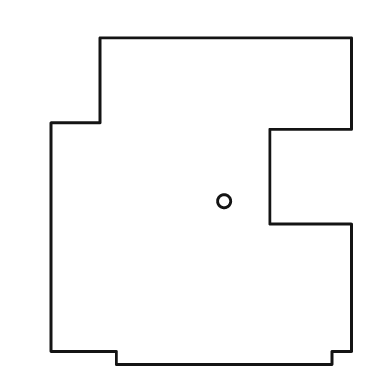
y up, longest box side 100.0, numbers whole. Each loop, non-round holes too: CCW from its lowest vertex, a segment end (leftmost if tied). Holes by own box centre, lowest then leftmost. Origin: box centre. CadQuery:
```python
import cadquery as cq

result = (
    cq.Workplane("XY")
    .moveTo(-26.0, -50.0)
    .lineTo(40.0, -50.0)
    .lineTo(40.0, -46.0)
    .lineTo(46.0, -46.0)
    .lineTo(46.0, -7.0)
    .lineTo(21.0, -7.0)
    .lineTo(21.0, 22.0)
    .lineTo(46.0, 22.0)
    .lineTo(46.0, 50.0)
    .lineTo(-31.0, 50.0)
    .lineTo(-31.0, 24.0)
    .lineTo(-46.0, 24.0)
    .lineTo(-46.0, -46.0)
    .lineTo(-26.0, -46.0)
    .close()
    .moveTo(7.0, 0.0)
    .circle(2.0)
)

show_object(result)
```